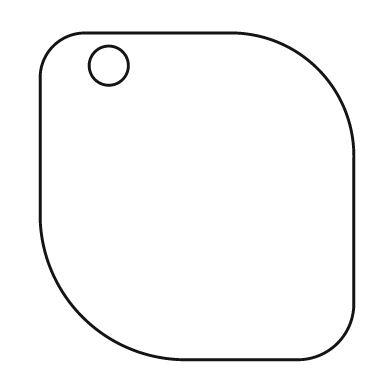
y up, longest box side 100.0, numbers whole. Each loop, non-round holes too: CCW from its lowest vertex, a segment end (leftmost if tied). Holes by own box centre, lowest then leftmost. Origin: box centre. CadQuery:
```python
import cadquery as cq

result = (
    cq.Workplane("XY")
    .moveTo(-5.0, -50.0)
    .lineTo(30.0, -50.0)
    .threePointArc((43.0, -45.0), (48.0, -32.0))
    .lineTo(48.0, 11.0)
    .threePointArc((37.0, 39.0), (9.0, 50.0))
    .lineTo(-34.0, 50.0)
    .threePointArc((-44.0, 46.0), (-48.0, 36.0))
    .lineTo(-48.0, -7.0)
    .threePointArc((-35.0, -37.0), (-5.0, -50.0))
    .close()
    .moveTo(-27.0, 40.0)
    .circle(6.0)
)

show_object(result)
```